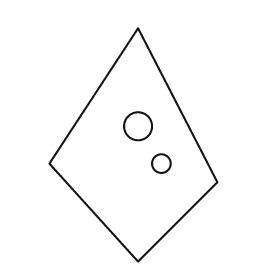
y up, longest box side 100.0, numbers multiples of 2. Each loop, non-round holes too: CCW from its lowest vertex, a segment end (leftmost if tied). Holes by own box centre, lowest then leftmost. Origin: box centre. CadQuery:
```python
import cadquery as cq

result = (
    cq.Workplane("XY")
    .moveTo(2.0, -50.0)
    .lineTo(36.0, -16.0)
    .lineTo(2.0, 50.0)
    .lineTo(-36.0, -8.0)
    .close()
    .moveTo(12.0, -8.0)
    .circle(4.0)
    .moveTo(2.0, 8.0)
    .circle(6.0)
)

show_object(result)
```